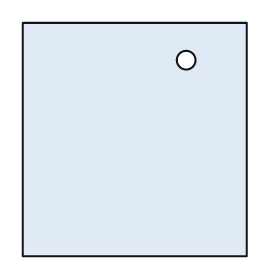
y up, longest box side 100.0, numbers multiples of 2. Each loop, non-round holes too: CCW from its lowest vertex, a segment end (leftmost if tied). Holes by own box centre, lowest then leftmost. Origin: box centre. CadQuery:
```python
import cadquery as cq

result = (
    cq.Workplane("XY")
    .moveTo(-48.0, -50.0)
    .lineTo(48.0, -50.0)
    .lineTo(48.0, 50.0)
    .lineTo(-48.0, 50.0)
    .close()
    .moveTo(22.0, 34.0)
    .circle(4.0)
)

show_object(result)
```